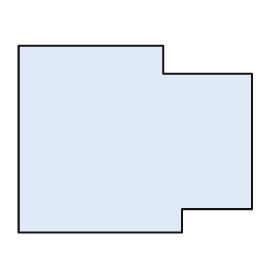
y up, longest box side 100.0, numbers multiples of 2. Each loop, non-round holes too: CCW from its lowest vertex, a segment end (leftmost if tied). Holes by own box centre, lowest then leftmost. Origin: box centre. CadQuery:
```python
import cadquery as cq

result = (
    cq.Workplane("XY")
    .moveTo(-50.0, -40.0)
    .lineTo(20.0, -40.0)
    .lineTo(20.0, -30.0)
    .lineTo(50.0, -30.0)
    .lineTo(50.0, 28.0)
    .lineTo(12.0, 28.0)
    .lineTo(12.0, 40.0)
    .lineTo(-50.0, 40.0)
    .close()
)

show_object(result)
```